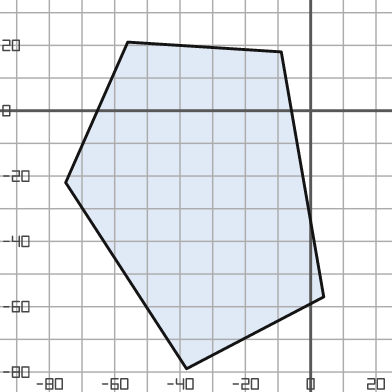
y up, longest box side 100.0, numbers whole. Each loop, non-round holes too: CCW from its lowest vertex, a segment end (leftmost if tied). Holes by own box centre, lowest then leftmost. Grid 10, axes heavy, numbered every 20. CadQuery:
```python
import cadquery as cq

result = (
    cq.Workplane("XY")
    .moveTo(-38.0, -79.0)
    .lineTo(4.0, -57.0)
    .lineTo(-9.0, 18.0)
    .lineTo(-56.0, 21.0)
    .lineTo(-75.0, -22.0)
    .close()
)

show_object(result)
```